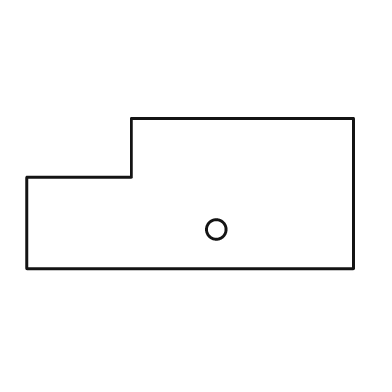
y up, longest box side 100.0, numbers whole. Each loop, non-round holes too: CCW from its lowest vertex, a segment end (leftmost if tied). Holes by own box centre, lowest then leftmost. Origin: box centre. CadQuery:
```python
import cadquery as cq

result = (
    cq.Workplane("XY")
    .moveTo(-50.0, -23.0)
    .lineTo(50.0, -23.0)
    .lineTo(50.0, 23.0)
    .lineTo(-18.0, 23.0)
    .lineTo(-18.0, 5.0)
    .lineTo(-50.0, 5.0)
    .close()
    .moveTo(8.0, -11.0)
    .circle(3.0)
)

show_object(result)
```